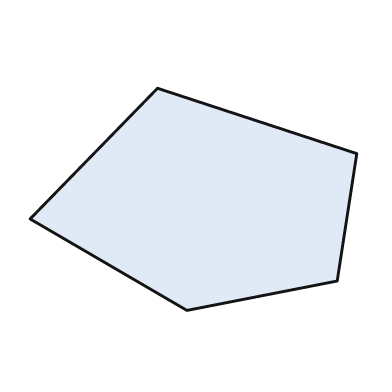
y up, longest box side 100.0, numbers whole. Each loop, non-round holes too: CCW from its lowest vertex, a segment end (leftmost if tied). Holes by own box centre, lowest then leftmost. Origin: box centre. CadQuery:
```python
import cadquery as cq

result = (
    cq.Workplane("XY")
    .moveTo(-2.0, -34.0)
    .lineTo(44.0, -25.0)
    .lineTo(50.0, 14.0)
    .lineTo(-11.0, 34.0)
    .lineTo(-50.0, -6.0)
    .close()
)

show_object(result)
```